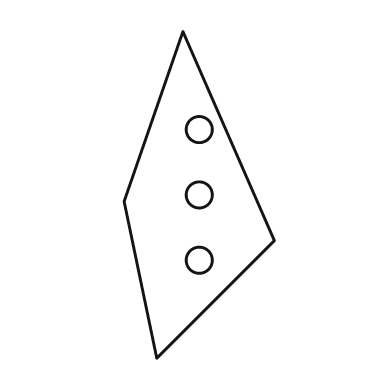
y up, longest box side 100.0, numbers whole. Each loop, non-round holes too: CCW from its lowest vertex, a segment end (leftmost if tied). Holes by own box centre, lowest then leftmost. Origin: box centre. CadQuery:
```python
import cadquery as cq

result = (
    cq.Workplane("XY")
    .moveTo(-13.0, -50.0)
    .lineTo(23.0, -14.0)
    .lineTo(-5.0, 50.0)
    .lineTo(-23.0, -2.0)
    .close()
    .moveTo(0.0, -20.0)
    .circle(4.0)
    .moveTo(0.0, 0.0)
    .circle(4.0)
    .moveTo(0.0, 20.0)
    .circle(4.0)
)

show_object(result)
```